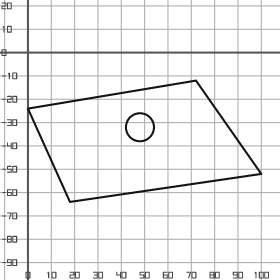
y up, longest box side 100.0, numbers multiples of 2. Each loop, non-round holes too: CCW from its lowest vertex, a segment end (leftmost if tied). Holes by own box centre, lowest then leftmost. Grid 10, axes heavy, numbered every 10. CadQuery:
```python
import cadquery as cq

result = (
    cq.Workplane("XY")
    .moveTo(18.0, -64.0)
    .lineTo(100.0, -52.0)
    .lineTo(72.0, -12.0)
    .lineTo(0.0, -24.0)
    .close()
    .moveTo(48.0, -32.0)
    .circle(6.0)
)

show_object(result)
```